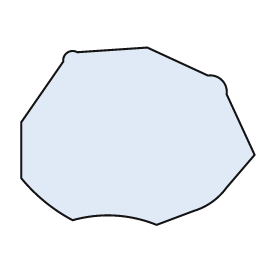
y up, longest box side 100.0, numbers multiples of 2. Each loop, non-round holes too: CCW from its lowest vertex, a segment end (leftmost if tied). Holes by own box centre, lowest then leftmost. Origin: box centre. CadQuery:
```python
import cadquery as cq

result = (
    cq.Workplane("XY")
    .moveTo(8.0, -38.0)
    .lineTo(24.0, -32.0)
    .threePointArc((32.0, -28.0), (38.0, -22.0))
    .lineTo(50.0, -8.0)
    .lineTo(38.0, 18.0)
    .threePointArc((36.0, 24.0), (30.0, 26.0))
    .lineTo(4.0, 38.0)
    .lineTo(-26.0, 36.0)
    .threePointArc((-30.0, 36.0), (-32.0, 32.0))
    .lineTo(-50.0, 6.0)
    .lineTo(-50.0, -18.0)
    .threePointArc((-40.0, -28.0), (-28.0, -36.0))
    .threePointArc((-10.0, -34.0), (8.0, -38.0))
    .close()
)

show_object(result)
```